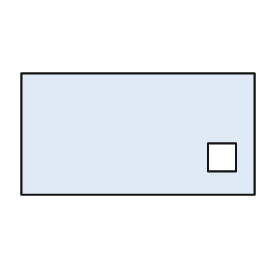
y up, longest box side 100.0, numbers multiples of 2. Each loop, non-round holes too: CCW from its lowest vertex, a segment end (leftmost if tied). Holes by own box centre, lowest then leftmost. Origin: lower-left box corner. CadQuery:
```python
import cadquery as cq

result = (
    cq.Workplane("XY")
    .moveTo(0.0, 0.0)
    .lineTo(100.0, 0.0)
    .lineTo(100.0, 52.0)
    .lineTo(0.0, 52.0)
    .close()
    .moveTo(80.0, 10.0)
    .lineTo(92.0, 10.0)
    .lineTo(92.0, 22.0)
    .lineTo(80.0, 22.0)
    .close()
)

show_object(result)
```